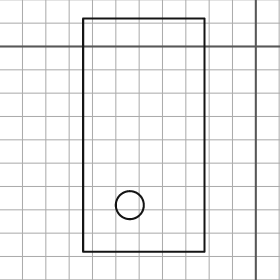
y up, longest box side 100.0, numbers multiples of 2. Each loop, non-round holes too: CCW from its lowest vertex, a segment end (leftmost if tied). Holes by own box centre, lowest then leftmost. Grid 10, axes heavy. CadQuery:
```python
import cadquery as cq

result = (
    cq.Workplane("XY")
    .moveTo(-74.0, -88.0)
    .lineTo(-22.0, -88.0)
    .lineTo(-22.0, 12.0)
    .lineTo(-74.0, 12.0)
    .close()
    .moveTo(-54.0, -68.0)
    .circle(6.0)
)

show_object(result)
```